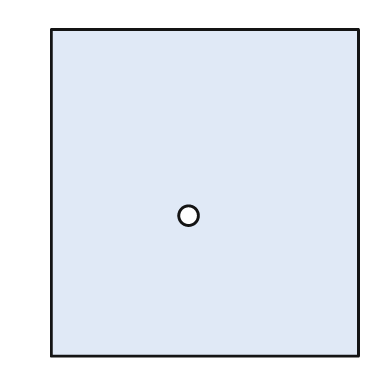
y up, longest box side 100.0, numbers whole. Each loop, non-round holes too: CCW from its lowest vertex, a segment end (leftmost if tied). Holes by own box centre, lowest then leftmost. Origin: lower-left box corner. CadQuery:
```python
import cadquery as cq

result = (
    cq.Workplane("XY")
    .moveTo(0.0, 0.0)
    .lineTo(94.0, 0.0)
    .lineTo(94.0, 100.0)
    .lineTo(0.0, 100.0)
    .close()
    .moveTo(42.0, 43.0)
    .circle(3.0)
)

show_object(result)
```